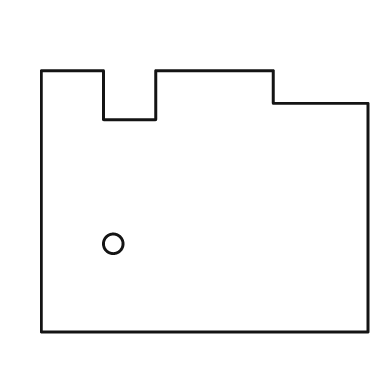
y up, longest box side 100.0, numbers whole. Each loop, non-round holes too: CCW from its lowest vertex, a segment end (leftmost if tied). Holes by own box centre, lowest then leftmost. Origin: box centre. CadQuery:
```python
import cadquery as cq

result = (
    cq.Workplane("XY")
    .moveTo(-50.0, -40.0)
    .lineTo(50.0, -40.0)
    .lineTo(50.0, 30.0)
    .lineTo(21.0, 30.0)
    .lineTo(21.0, 40.0)
    .lineTo(-15.0, 40.0)
    .lineTo(-15.0, 25.0)
    .lineTo(-31.0, 25.0)
    .lineTo(-31.0, 40.0)
    .lineTo(-50.0, 40.0)
    .close()
    .moveTo(-28.0, -13.0)
    .circle(3.0)
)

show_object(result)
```